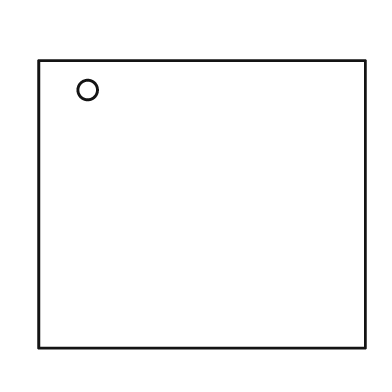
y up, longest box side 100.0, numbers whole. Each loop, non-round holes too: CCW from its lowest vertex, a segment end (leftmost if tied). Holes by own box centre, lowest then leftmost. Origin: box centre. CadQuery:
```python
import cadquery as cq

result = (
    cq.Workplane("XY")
    .moveTo(-50.0, -44.0)
    .lineTo(50.0, -44.0)
    .lineTo(50.0, 44.0)
    .lineTo(-50.0, 44.0)
    .close()
    .moveTo(-35.0, 35.0)
    .circle(3.0)
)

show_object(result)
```